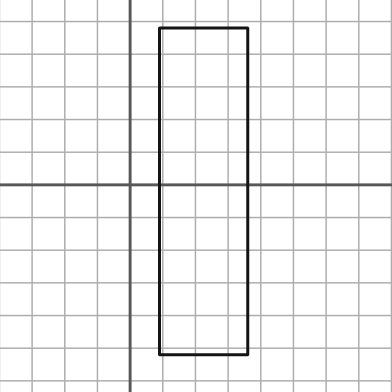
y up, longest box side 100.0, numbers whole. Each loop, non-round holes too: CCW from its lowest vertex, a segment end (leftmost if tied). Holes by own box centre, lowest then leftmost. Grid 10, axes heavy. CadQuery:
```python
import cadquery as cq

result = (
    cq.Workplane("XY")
    .moveTo(9.0, -52.0)
    .lineTo(36.0, -52.0)
    .lineTo(36.0, 48.0)
    .lineTo(9.0, 48.0)
    .close()
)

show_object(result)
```